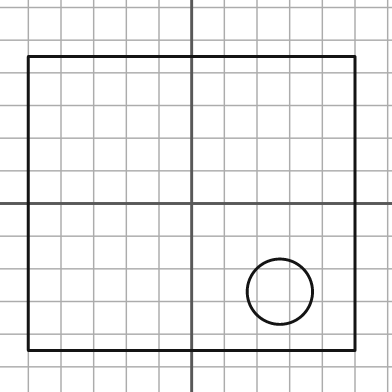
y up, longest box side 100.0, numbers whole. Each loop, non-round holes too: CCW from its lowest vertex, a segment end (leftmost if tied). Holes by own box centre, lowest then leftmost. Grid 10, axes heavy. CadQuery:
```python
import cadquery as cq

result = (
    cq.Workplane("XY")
    .moveTo(-50.0, -45.0)
    .lineTo(50.0, -45.0)
    .lineTo(50.0, 45.0)
    .lineTo(-50.0, 45.0)
    .close()
    .moveTo(27.0, -27.0)
    .circle(10.0)
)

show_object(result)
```